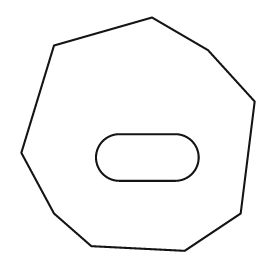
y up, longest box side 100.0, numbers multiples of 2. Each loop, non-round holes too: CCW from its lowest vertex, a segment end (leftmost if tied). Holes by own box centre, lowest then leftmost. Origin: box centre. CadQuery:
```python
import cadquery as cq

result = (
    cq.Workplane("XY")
    .moveTo(20.0, -50.0)
    .lineTo(44.0, -34.0)
    .lineTo(50.0, 14.0)
    .lineTo(30.0, 36.0)
    .lineTo(6.0, 50.0)
    .lineTo(-36.0, 38.0)
    .lineTo(-50.0, -8.0)
    .lineTo(-36.0, -34.0)
    .lineTo(-20.0, -48.0)
    .close()
    .moveTo(-8.0, -20.0)
    .lineTo(16.0, -20.0)
    .threePointArc((26.0, -10.0), (16.0, 0.0))
    .lineTo(-8.0, 0.0)
    .threePointArc((-18.0, -10.0), (-8.0, -20.0))
    .close()
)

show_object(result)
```